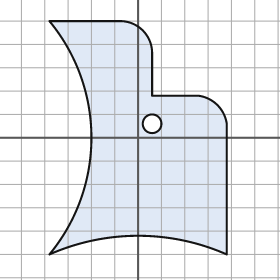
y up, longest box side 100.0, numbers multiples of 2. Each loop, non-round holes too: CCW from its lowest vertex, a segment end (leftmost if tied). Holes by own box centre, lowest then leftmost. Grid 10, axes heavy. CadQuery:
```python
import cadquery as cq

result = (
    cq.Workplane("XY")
    .moveTo(-38.0, -50.0)
    .threePointArc((0.0, -42.0), (38.0, -50.0))
    .lineTo(38.0, 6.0)
    .threePointArc((34.0, 14.0), (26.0, 18.0))
    .lineTo(6.0, 18.0)
    .lineTo(6.0, 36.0)
    .threePointArc((2.0, 46.0), (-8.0, 50.0))
    .lineTo(-38.0, 50.0)
    .threePointArc((-20.0, 0.0), (-38.0, -50.0))
    .close()
    .moveTo(6.0, 6.0)
    .circle(4.0)
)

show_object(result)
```